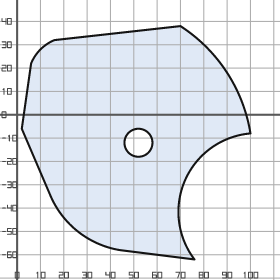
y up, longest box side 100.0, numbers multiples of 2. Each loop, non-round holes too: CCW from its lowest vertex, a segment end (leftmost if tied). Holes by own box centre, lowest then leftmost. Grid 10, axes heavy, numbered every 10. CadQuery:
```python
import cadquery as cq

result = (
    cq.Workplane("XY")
    .moveTo(76.0, -62.0)
    .threePointArc((72.0, -28.0), (100.0, -8.0))
    .threePointArc((90.0, 18.0), (70.0, 38.0))
    .lineTo(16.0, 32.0)
    .threePointArc((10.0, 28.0), (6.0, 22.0))
    .lineTo(2.0, -6.0)
    .lineTo(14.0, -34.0)
    .threePointArc((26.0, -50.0), (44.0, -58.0))
    .close()
    .moveTo(52.0, -12.0)
    .circle(6.0)
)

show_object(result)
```